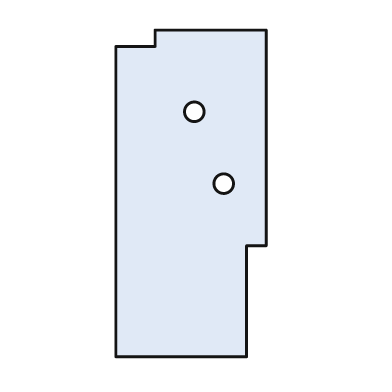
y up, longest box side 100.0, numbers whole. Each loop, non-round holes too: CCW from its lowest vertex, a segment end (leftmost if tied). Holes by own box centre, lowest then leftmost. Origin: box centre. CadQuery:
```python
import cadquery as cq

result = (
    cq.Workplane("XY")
    .moveTo(-23.0, -50.0)
    .lineTo(17.0, -50.0)
    .lineTo(17.0, -16.0)
    .lineTo(23.0, -16.0)
    .lineTo(23.0, 50.0)
    .lineTo(-11.0, 50.0)
    .lineTo(-11.0, 45.0)
    .lineTo(-23.0, 45.0)
    .close()
    .moveTo(10.0, 3.0)
    .circle(3.0)
    .moveTo(1.0, 25.0)
    .circle(3.0)
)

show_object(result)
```